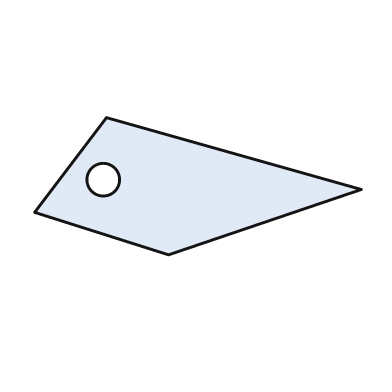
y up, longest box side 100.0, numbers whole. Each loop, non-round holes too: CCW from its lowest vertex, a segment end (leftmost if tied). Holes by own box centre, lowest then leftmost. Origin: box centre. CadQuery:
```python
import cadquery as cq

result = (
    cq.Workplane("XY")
    .moveTo(-9.0, -21.0)
    .lineTo(50.0, -1.0)
    .lineTo(-28.0, 21.0)
    .lineTo(-50.0, -8.0)
    .close()
    .moveTo(-29.0, 2.0)
    .circle(5.0)
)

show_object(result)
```